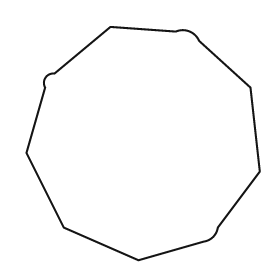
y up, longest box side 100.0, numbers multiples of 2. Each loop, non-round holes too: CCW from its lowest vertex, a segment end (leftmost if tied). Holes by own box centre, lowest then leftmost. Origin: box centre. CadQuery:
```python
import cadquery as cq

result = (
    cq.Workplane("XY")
    .moveTo(-2.0, -50.0)
    .lineTo(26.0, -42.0)
    .threePointArc((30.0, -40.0), (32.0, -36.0))
    .lineTo(50.0, -12.0)
    .lineTo(46.0, 24.0)
    .lineTo(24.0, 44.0)
    .threePointArc((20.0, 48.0), (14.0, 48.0))
    .lineTo(-14.0, 50.0)
    .lineTo(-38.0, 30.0)
    .threePointArc((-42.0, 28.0), (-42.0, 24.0))
    .lineTo(-50.0, -4.0)
    .lineTo(-34.0, -36.0)
    .close()
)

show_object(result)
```